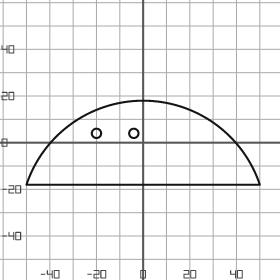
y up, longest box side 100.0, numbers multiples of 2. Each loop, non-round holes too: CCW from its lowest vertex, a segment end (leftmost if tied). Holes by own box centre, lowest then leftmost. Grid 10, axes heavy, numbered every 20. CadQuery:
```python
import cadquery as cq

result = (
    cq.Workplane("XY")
    .moveTo(-50.0, -18.0)
    .lineTo(50.0, -18.0)
    .threePointArc((0.0, 18.0), (-50.0, -18.0))
    .close()
    .moveTo(-20.0, 4.0)
    .circle(2.0)
    .moveTo(-4.0, 4.0)
    .circle(2.0)
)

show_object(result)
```